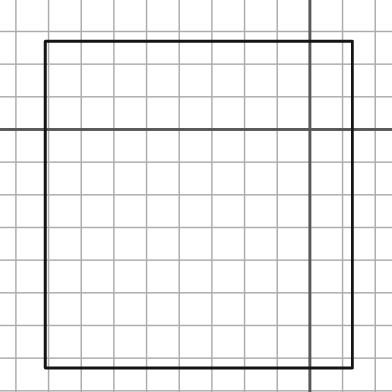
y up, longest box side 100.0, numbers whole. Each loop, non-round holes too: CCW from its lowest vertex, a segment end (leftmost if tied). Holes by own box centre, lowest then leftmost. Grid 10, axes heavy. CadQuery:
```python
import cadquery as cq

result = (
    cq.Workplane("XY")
    .moveTo(-81.0, -73.0)
    .lineTo(13.0, -73.0)
    .lineTo(13.0, 27.0)
    .lineTo(-81.0, 27.0)
    .close()
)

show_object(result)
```